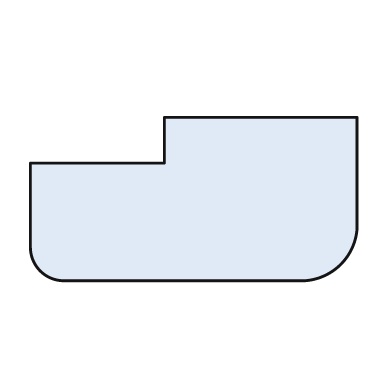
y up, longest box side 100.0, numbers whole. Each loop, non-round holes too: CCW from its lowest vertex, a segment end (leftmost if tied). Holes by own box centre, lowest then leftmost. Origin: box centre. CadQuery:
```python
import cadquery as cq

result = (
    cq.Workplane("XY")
    .moveTo(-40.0, -25.0)
    .lineTo(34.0, -25.0)
    .threePointArc((45.0, -20.0), (50.0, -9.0))
    .lineTo(50.0, 25.0)
    .lineTo(-9.0, 25.0)
    .lineTo(-9.0, 11.0)
    .lineTo(-50.0, 11.0)
    .lineTo(-50.0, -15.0)
    .threePointArc((-47.0, -22.0), (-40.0, -25.0))
    .close()
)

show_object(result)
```